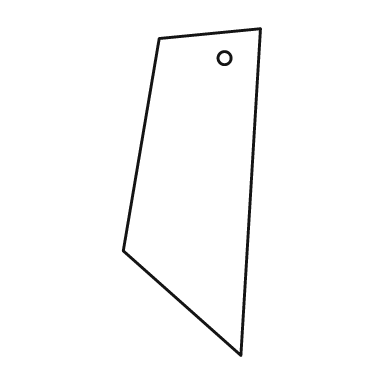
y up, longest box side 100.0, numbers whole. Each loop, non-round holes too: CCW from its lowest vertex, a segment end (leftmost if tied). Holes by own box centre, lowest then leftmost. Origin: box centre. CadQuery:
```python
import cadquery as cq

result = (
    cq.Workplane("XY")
    .moveTo(15.0, -50.0)
    .lineTo(21.0, 50.0)
    .lineTo(-10.0, 47.0)
    .lineTo(-21.0, -18.0)
    .close()
    .moveTo(10.0, 41.0)
    .circle(2.0)
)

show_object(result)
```